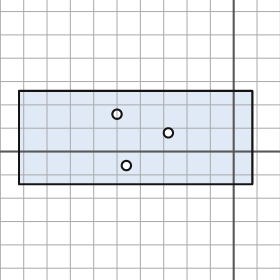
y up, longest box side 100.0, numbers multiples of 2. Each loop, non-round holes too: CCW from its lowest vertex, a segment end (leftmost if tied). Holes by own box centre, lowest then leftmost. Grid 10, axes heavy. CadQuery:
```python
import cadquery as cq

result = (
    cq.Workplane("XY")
    .moveTo(-92.0, -14.0)
    .lineTo(8.0, -14.0)
    .lineTo(8.0, 26.0)
    .lineTo(-92.0, 26.0)
    .close()
    .moveTo(-46.0, -6.0)
    .circle(2.0)
    .moveTo(-28.0, 8.0)
    .circle(2.0)
    .moveTo(-50.0, 16.0)
    .circle(2.0)
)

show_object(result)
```